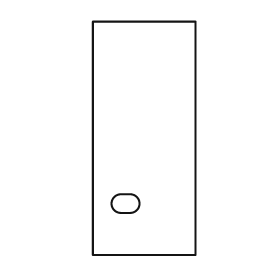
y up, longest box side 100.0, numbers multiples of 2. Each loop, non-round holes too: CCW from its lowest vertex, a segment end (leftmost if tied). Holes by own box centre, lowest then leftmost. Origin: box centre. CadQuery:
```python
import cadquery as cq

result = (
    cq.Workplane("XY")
    .moveTo(-22.0, -50.0)
    .lineTo(22.0, -50.0)
    .lineTo(22.0, 50.0)
    .lineTo(-22.0, 50.0)
    .close()
    .moveTo(-10.0, -32.0)
    .lineTo(-6.0, -32.0)
    .threePointArc((-2.0, -28.0), (-6.0, -24.0))
    .lineTo(-10.0, -24.0)
    .threePointArc((-14.0, -28.0), (-10.0, -32.0))
    .close()
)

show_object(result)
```